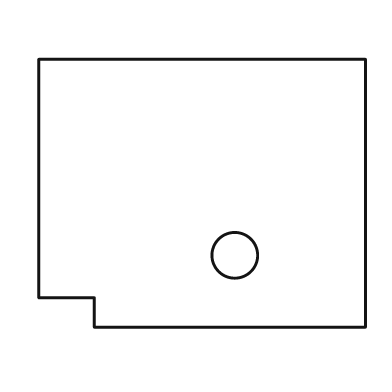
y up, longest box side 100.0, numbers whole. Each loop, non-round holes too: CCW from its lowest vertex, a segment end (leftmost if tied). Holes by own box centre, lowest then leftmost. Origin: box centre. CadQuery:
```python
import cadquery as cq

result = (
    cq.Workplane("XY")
    .moveTo(-33.0, -41.0)
    .lineTo(50.0, -41.0)
    .lineTo(50.0, 41.0)
    .lineTo(-50.0, 41.0)
    .lineTo(-50.0, -32.0)
    .lineTo(-33.0, -32.0)
    .close()
    .moveTo(10.0, -19.0)
    .circle(7.0)
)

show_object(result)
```